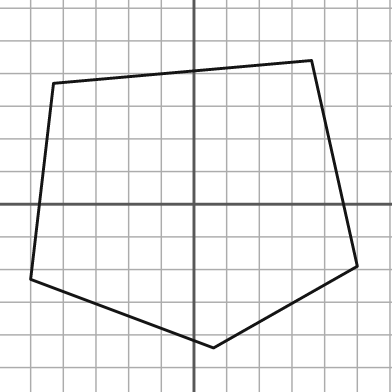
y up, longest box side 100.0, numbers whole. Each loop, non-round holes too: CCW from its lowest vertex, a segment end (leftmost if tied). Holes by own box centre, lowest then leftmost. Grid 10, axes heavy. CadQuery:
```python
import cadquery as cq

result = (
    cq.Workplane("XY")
    .moveTo(6.0, -44.0)
    .lineTo(50.0, -19.0)
    .lineTo(36.0, 44.0)
    .lineTo(-43.0, 37.0)
    .lineTo(-50.0, -23.0)
    .close()
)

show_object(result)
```